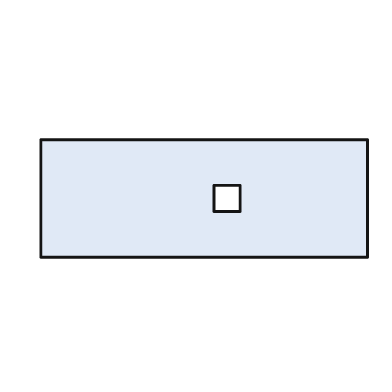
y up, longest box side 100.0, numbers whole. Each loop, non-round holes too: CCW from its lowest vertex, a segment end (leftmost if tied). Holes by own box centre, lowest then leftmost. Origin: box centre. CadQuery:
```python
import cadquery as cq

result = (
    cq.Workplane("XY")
    .moveTo(-50.0, -18.0)
    .lineTo(50.0, -18.0)
    .lineTo(50.0, 18.0)
    .lineTo(-50.0, 18.0)
    .close()
    .moveTo(3.0, -4.0)
    .lineTo(11.0, -4.0)
    .lineTo(11.0, 4.0)
    .lineTo(3.0, 4.0)
    .close()
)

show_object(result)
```